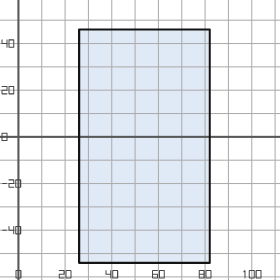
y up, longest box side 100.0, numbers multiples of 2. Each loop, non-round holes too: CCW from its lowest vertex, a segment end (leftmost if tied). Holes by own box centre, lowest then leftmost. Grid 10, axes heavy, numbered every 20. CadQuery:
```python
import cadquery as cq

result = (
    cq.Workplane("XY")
    .moveTo(26.0, -54.0)
    .lineTo(82.0, -54.0)
    .lineTo(82.0, 46.0)
    .lineTo(26.0, 46.0)
    .close()
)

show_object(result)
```